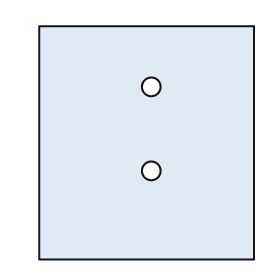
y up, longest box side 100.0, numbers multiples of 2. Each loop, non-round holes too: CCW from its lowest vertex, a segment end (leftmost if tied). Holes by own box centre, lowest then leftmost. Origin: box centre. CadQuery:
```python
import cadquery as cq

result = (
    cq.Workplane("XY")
    .moveTo(-46.0, -50.0)
    .lineTo(46.0, -50.0)
    .lineTo(46.0, 50.0)
    .lineTo(-46.0, 50.0)
    .close()
    .moveTo(2.0, -12.0)
    .circle(4.0)
    .moveTo(2.0, 24.0)
    .circle(4.0)
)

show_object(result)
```